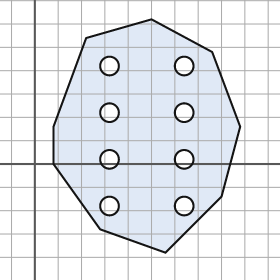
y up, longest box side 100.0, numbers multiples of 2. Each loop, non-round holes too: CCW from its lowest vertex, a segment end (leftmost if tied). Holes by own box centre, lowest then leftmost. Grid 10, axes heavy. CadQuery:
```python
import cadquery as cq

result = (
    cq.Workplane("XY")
    .moveTo(56.0, -38.0)
    .lineTo(80.0, -14.0)
    .lineTo(88.0, 16.0)
    .lineTo(76.0, 48.0)
    .lineTo(50.0, 62.0)
    .lineTo(22.0, 54.0)
    .lineTo(8.0, 16.0)
    .lineTo(8.0, 0.0)
    .lineTo(28.0, -28.0)
    .close()
    .moveTo(32.0, -18.0)
    .circle(4.0)
    .moveTo(64.0, -18.0)
    .circle(4.0)
    .moveTo(32.0, 2.0)
    .circle(4.0)
    .moveTo(64.0, 2.0)
    .circle(4.0)
    .moveTo(32.0, 22.0)
    .circle(4.0)
    .moveTo(64.0, 22.0)
    .circle(4.0)
    .moveTo(32.0, 42.0)
    .circle(4.0)
    .moveTo(64.0, 42.0)
    .circle(4.0)
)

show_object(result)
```